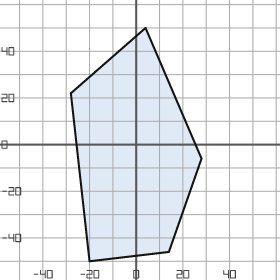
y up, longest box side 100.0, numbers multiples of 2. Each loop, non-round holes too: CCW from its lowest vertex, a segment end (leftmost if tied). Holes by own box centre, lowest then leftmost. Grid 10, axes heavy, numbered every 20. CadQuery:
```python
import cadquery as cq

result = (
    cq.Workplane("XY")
    .moveTo(-20.0, -50.0)
    .lineTo(14.0, -46.0)
    .lineTo(28.0, -6.0)
    .lineTo(4.0, 50.0)
    .lineTo(-28.0, 22.0)
    .close()
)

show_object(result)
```